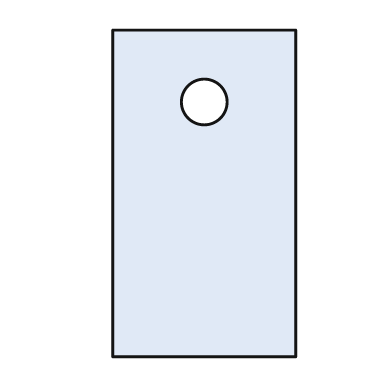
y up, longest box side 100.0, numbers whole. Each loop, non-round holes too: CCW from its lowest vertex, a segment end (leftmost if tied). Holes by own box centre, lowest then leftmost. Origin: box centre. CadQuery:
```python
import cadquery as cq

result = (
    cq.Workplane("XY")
    .moveTo(-28.0, -50.0)
    .lineTo(28.0, -50.0)
    .lineTo(28.0, 50.0)
    .lineTo(-28.0, 50.0)
    .close()
    .moveTo(0.0, 28.0)
    .circle(7.0)
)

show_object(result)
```